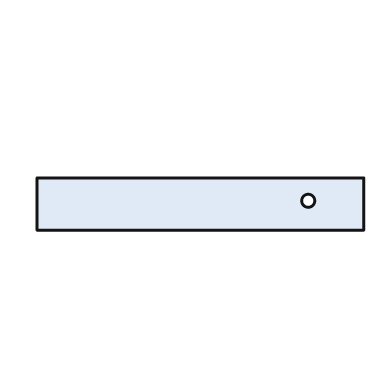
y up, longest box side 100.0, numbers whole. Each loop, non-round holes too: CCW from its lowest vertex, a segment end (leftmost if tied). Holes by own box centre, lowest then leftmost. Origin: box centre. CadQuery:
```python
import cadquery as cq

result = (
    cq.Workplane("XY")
    .moveTo(-50.0, -8.0)
    .lineTo(50.0, -8.0)
    .lineTo(50.0, 8.0)
    .lineTo(-50.0, 8.0)
    .close()
    .moveTo(33.0, 1.0)
    .circle(2.0)
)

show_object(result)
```